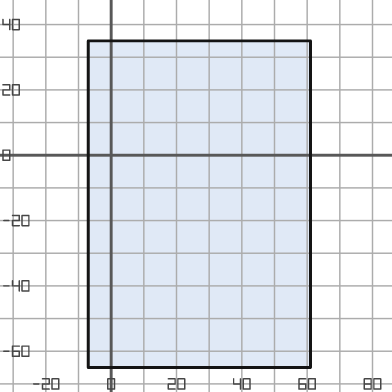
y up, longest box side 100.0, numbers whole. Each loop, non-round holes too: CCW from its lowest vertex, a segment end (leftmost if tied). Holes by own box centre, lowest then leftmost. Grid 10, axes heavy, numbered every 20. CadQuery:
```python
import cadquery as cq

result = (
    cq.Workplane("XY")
    .moveTo(-7.0, -65.0)
    .lineTo(61.0, -65.0)
    .lineTo(61.0, 35.0)
    .lineTo(-7.0, 35.0)
    .close()
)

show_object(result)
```